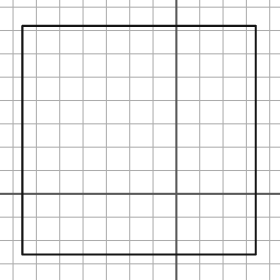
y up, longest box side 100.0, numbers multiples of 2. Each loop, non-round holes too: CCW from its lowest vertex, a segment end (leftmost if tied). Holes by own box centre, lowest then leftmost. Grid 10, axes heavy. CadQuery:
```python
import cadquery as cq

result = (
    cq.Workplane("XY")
    .moveTo(-66.0, -26.0)
    .lineTo(34.0, -26.0)
    .lineTo(34.0, 72.0)
    .lineTo(-66.0, 72.0)
    .close()
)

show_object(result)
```